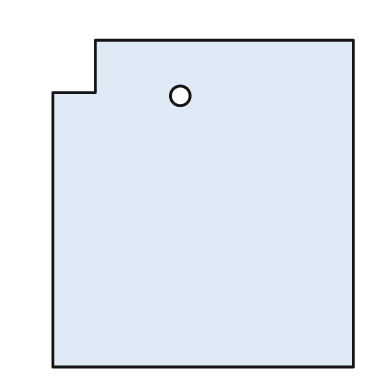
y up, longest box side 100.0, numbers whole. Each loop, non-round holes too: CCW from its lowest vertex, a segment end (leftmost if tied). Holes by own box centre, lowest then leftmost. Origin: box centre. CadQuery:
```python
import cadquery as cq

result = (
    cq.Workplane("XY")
    .moveTo(-46.0, -50.0)
    .lineTo(46.0, -50.0)
    .lineTo(46.0, 50.0)
    .lineTo(-33.0, 50.0)
    .lineTo(-33.0, 34.0)
    .lineTo(-46.0, 34.0)
    .close()
    .moveTo(-7.0, 33.0)
    .circle(3.0)
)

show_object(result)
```